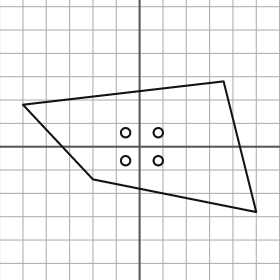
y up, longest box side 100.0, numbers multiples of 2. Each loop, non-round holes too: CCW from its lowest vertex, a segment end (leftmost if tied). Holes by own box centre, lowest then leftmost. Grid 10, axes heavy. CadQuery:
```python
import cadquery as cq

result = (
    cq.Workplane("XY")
    .moveTo(50.0, -28.0)
    .lineTo(36.0, 28.0)
    .lineTo(-50.0, 18.0)
    .lineTo(-20.0, -14.0)
    .close()
    .moveTo(-6.0, -6.0)
    .circle(2.0)
    .moveTo(8.0, -6.0)
    .circle(2.0)
    .moveTo(-6.0, 6.0)
    .circle(2.0)
    .moveTo(8.0, 6.0)
    .circle(2.0)
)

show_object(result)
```